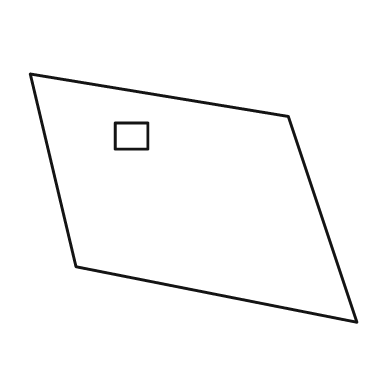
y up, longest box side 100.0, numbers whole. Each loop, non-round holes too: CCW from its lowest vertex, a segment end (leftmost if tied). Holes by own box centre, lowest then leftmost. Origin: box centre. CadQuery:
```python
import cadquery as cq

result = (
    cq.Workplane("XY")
    .moveTo(50.0, -38.0)
    .lineTo(29.0, 25.0)
    .lineTo(-50.0, 38.0)
    .lineTo(-36.0, -21.0)
    .close()
    .moveTo(-24.0, 15.0)
    .lineTo(-14.0, 15.0)
    .lineTo(-14.0, 23.0)
    .lineTo(-24.0, 23.0)
    .close()
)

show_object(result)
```